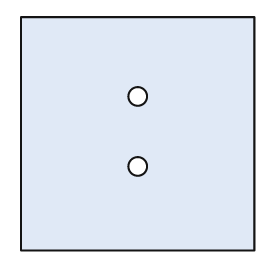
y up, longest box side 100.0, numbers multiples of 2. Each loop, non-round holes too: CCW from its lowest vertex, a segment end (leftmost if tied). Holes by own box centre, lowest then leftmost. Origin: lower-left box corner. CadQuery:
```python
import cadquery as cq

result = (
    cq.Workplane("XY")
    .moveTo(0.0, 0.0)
    .lineTo(100.0, 0.0)
    .lineTo(100.0, 100.0)
    .lineTo(0.0, 100.0)
    .close()
    .moveTo(50.0, 36.0)
    .circle(4.0)
    .moveTo(50.0, 66.0)
    .circle(4.0)
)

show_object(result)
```